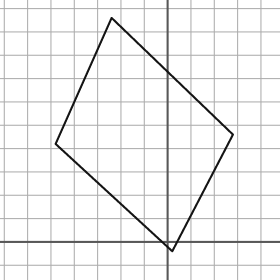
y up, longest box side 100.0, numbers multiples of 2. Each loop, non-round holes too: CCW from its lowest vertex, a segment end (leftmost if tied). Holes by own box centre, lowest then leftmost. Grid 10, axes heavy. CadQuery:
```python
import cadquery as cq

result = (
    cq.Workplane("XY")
    .moveTo(2.0, -4.0)
    .lineTo(28.0, 46.0)
    .lineTo(-24.0, 96.0)
    .lineTo(-48.0, 42.0)
    .close()
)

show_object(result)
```